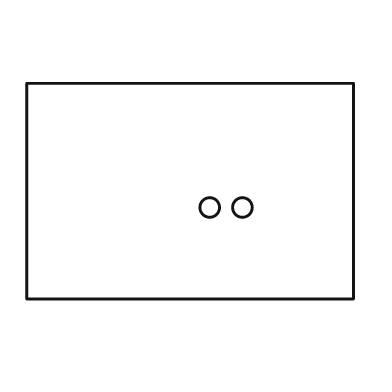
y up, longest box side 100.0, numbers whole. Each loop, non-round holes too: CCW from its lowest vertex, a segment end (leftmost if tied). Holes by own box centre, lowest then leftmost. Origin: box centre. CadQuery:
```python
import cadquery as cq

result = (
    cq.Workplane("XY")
    .moveTo(-50.0, -33.0)
    .lineTo(50.0, -33.0)
    .lineTo(50.0, 33.0)
    .lineTo(-50.0, 33.0)
    .close()
    .moveTo(6.0, -5.0)
    .circle(3.0)
    .moveTo(16.0, -5.0)
    .circle(3.0)
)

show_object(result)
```